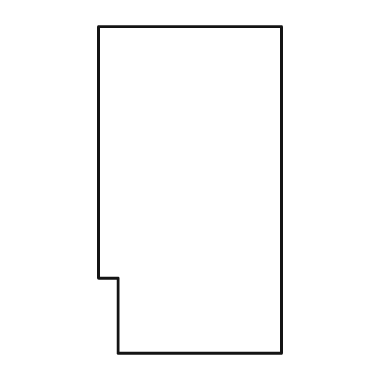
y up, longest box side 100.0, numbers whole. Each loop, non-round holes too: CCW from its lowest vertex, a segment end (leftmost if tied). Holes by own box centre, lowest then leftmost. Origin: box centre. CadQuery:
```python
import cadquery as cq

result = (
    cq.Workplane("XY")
    .moveTo(-22.0, -50.0)
    .lineTo(28.0, -50.0)
    .lineTo(28.0, 50.0)
    .lineTo(-28.0, 50.0)
    .lineTo(-28.0, -27.0)
    .lineTo(-22.0, -27.0)
    .close()
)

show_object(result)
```